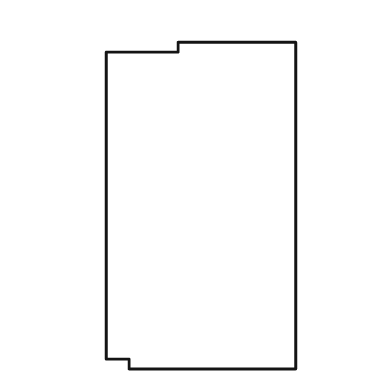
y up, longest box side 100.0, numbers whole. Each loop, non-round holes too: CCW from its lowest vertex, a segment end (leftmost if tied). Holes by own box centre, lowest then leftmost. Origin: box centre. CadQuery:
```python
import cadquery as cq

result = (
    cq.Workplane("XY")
    .moveTo(-22.0, -50.0)
    .lineTo(29.0, -50.0)
    .lineTo(29.0, 50.0)
    .lineTo(-7.0, 50.0)
    .lineTo(-7.0, 47.0)
    .lineTo(-29.0, 47.0)
    .lineTo(-29.0, -47.0)
    .lineTo(-22.0, -47.0)
    .close()
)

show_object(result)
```